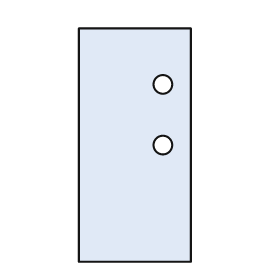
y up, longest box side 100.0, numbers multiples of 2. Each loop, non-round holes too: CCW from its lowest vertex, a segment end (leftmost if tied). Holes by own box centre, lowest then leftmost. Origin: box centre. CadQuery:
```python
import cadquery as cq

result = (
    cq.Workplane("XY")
    .moveTo(-24.0, -50.0)
    .lineTo(24.0, -50.0)
    .lineTo(24.0, 50.0)
    .lineTo(-24.0, 50.0)
    .close()
    .moveTo(12.0, 0.0)
    .circle(4.0)
    .moveTo(12.0, 26.0)
    .circle(4.0)
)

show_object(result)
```